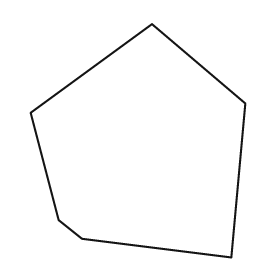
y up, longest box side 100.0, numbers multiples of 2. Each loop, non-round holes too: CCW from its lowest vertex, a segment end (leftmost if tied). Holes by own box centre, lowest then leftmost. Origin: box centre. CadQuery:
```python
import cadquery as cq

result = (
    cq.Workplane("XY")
    .moveTo(40.0, -50.0)
    .lineTo(46.0, 16.0)
    .lineTo(6.0, 50.0)
    .lineTo(-46.0, 12.0)
    .lineTo(-34.0, -34.0)
    .lineTo(-24.0, -42.0)
    .close()
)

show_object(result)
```